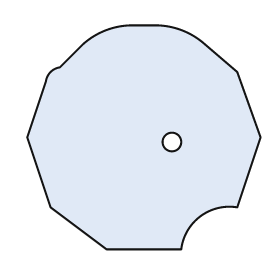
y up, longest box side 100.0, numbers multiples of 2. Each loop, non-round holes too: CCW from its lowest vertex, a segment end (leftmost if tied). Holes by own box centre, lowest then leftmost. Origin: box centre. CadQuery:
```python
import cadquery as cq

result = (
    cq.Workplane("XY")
    .moveTo(-16.0, -48.0)
    .lineTo(16.0, -48.0)
    .threePointArc((24.0, -34.0), (40.0, -30.0))
    .lineTo(50.0, 0.0)
    .lineTo(40.0, 28.0)
    .lineTo(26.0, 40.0)
    .threePointArc((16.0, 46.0), (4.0, 48.0))
    .lineTo(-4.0, 48.0)
    .threePointArc((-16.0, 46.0), (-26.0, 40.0))
    .lineTo(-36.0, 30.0)
    .threePointArc((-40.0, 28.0), (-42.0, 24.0))
    .lineTo(-50.0, 0.0)
    .lineTo(-40.0, -30.0)
    .close()
    .moveTo(12.0, -2.0)
    .circle(4.0)
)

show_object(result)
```